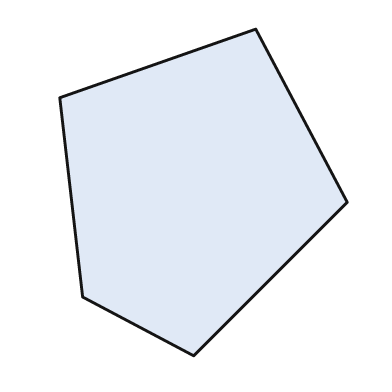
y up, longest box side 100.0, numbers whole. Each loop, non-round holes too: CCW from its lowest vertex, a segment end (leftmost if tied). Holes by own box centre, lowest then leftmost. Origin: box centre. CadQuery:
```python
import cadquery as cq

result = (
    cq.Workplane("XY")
    .moveTo(-3.0, -50.0)
    .lineTo(44.0, -3.0)
    .lineTo(16.0, 50.0)
    .lineTo(-44.0, 29.0)
    .lineTo(-37.0, -32.0)
    .close()
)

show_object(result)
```